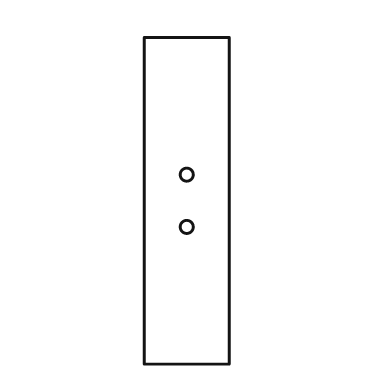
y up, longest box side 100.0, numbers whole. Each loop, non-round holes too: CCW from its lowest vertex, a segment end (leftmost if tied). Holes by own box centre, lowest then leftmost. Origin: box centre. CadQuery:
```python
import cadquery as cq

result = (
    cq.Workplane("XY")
    .moveTo(-13.0, -50.0)
    .lineTo(13.0, -50.0)
    .lineTo(13.0, 50.0)
    .lineTo(-13.0, 50.0)
    .close()
    .moveTo(0.0, -8.0)
    .circle(2.0)
    .moveTo(0.0, 8.0)
    .circle(2.0)
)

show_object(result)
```